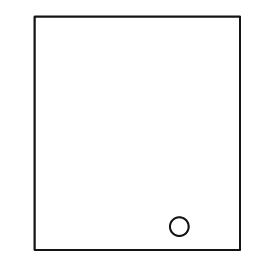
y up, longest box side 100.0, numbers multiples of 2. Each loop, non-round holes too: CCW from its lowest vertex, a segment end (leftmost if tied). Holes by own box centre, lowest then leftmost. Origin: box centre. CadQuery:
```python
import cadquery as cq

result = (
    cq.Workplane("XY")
    .moveTo(-44.0, -50.0)
    .lineTo(44.0, -50.0)
    .lineTo(44.0, 50.0)
    .lineTo(-44.0, 50.0)
    .close()
    .moveTo(18.0, -40.0)
    .circle(4.0)
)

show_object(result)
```